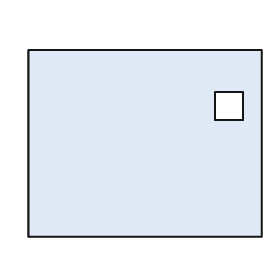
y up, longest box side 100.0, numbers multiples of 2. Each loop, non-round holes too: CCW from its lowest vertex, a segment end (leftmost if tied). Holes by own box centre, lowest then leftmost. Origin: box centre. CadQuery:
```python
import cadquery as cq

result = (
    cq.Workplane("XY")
    .moveTo(-50.0, -40.0)
    .lineTo(50.0, -40.0)
    .lineTo(50.0, 40.0)
    .lineTo(-50.0, 40.0)
    .close()
    .moveTo(30.0, 10.0)
    .lineTo(42.0, 10.0)
    .lineTo(42.0, 22.0)
    .lineTo(30.0, 22.0)
    .close()
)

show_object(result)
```